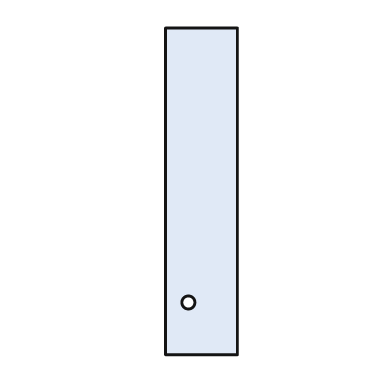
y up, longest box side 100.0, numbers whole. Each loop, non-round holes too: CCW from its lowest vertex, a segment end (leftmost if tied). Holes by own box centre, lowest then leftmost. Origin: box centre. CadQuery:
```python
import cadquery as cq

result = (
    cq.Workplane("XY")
    .moveTo(-11.0, -50.0)
    .lineTo(11.0, -50.0)
    .lineTo(11.0, 50.0)
    .lineTo(-11.0, 50.0)
    .close()
    .moveTo(-4.0, -34.0)
    .circle(2.0)
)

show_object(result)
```